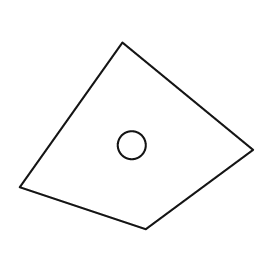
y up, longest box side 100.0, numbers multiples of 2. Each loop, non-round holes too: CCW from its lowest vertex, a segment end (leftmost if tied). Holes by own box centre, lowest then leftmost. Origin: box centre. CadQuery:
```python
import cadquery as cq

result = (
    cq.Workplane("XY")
    .moveTo(4.0, -40.0)
    .lineTo(50.0, -6.0)
    .lineTo(-6.0, 40.0)
    .lineTo(-50.0, -22.0)
    .close()
    .moveTo(-2.0, -4.0)
    .circle(6.0)
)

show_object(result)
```